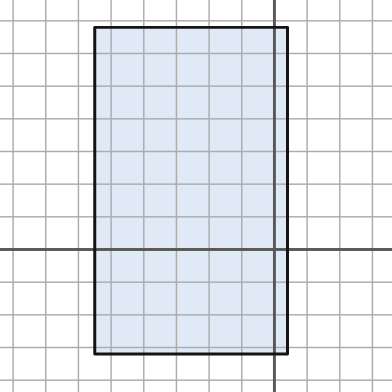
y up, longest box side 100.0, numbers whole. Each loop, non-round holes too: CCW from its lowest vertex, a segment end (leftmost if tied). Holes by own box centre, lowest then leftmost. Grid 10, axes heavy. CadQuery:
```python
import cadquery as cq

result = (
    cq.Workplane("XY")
    .moveTo(-55.0, -32.0)
    .lineTo(4.0, -32.0)
    .lineTo(4.0, 68.0)
    .lineTo(-55.0, 68.0)
    .close()
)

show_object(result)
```